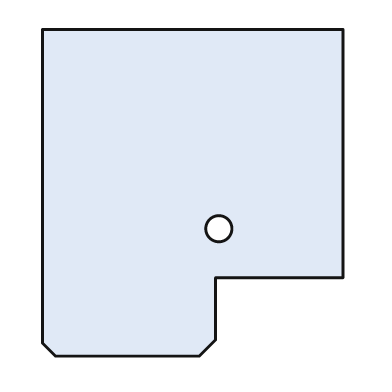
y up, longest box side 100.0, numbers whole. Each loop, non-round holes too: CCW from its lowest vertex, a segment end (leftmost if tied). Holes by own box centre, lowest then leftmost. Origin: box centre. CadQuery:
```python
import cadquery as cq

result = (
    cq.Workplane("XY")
    .moveTo(-42.0, -50.0)
    .lineTo(2.0, -50.0)
    .lineTo(7.0, -45.0)
    .lineTo(7.0, -26.0)
    .lineTo(46.0, -26.0)
    .lineTo(46.0, 50.0)
    .lineTo(-46.0, 50.0)
    .lineTo(-46.0, -46.0)
    .close()
    .moveTo(8.0, -11.0)
    .circle(4.0)
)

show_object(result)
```